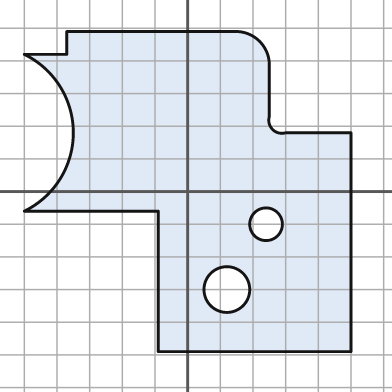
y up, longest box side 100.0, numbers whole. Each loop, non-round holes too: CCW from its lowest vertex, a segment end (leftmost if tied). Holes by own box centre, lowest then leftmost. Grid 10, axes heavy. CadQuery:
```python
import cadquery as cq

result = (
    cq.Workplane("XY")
    .moveTo(-9.0, -49.0)
    .lineTo(50.0, -49.0)
    .lineTo(50.0, 18.0)
    .lineTo(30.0, 18.0)
    .threePointArc((26.0, 19.0), (25.0, 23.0))
    .lineTo(25.0, 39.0)
    .threePointArc((22.0, 46.0), (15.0, 49.0))
    .lineTo(-37.0, 49.0)
    .lineTo(-37.0, 42.0)
    .lineTo(-50.0, 42.0)
    .threePointArc((-35.0, 18.0), (-50.0, -6.0))
    .lineTo(-9.0, -6.0)
    .close()
    .moveTo(12.0, -30.0)
    .circle(7.0)
    .moveTo(24.0, -10.0)
    .circle(5.0)
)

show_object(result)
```